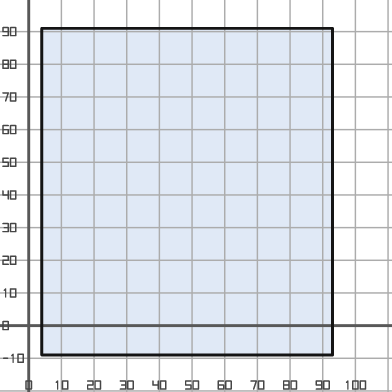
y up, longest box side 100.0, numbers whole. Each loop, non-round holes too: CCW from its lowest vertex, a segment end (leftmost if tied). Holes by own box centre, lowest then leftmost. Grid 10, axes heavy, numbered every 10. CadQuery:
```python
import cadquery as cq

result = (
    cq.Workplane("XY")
    .moveTo(4.0, -9.0)
    .lineTo(93.0, -9.0)
    .lineTo(93.0, 91.0)
    .lineTo(4.0, 91.0)
    .close()
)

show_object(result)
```